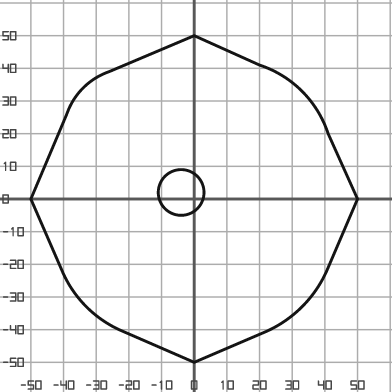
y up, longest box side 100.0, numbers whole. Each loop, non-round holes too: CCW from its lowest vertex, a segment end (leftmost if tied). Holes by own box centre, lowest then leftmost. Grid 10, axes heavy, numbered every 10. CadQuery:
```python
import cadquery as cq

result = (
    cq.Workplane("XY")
    .moveTo(0.0, -50.0)
    .lineTo(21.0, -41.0)
    .threePointArc((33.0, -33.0), (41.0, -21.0))
    .lineTo(50.0, 0.0)
    .lineTo(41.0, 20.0)
    .threePointArc((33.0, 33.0), (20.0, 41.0))
    .lineTo(0.0, 50.0)
    .lineTo(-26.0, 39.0)
    .threePointArc((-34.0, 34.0), (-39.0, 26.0))
    .lineTo(-50.0, 0.0)
    .lineTo(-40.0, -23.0)
    .threePointArc((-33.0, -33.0), (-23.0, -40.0))
    .close()
    .moveTo(-4.0, 2.0)
    .circle(7.0)
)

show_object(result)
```